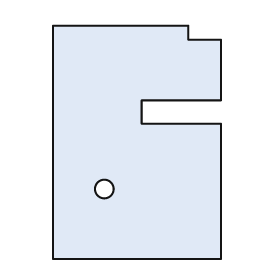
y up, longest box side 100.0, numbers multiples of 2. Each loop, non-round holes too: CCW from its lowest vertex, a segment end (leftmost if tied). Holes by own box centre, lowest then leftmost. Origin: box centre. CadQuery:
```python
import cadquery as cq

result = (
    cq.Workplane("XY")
    .moveTo(-36.0, -50.0)
    .lineTo(36.0, -50.0)
    .lineTo(36.0, 8.0)
    .lineTo(2.0, 8.0)
    .lineTo(2.0, 18.0)
    .lineTo(36.0, 18.0)
    .lineTo(36.0, 44.0)
    .lineTo(22.0, 44.0)
    .lineTo(22.0, 50.0)
    .lineTo(-36.0, 50.0)
    .close()
    .moveTo(-14.0, -20.0)
    .circle(4.0)
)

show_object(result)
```